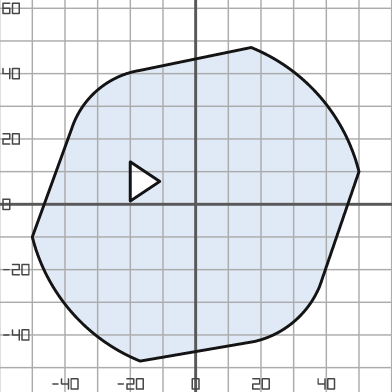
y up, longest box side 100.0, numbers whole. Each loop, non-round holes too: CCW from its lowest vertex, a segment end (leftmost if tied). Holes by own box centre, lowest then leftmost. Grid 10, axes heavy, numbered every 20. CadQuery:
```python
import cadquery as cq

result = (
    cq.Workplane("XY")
    .moveTo(-17.0, -48.0)
    .lineTo(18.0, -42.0)
    .threePointArc((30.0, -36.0), (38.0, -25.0))
    .lineTo(50.0, 10.0)
    .threePointArc((38.0, 33.0), (17.0, 48.0))
    .lineTo(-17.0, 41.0)
    .threePointArc((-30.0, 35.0), (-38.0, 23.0))
    .lineTo(-50.0, -10.0)
    .threePointArc((-38.0, -33.0), (-17.0, -48.0))
    .close()
    .moveTo(-20.0, 1.0)
    .lineTo(-11.0, 7.0)
    .lineTo(-20.0, 13.0)
    .close()
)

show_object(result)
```